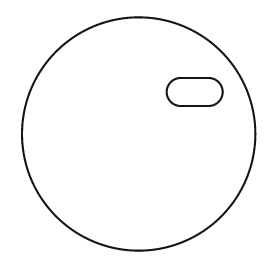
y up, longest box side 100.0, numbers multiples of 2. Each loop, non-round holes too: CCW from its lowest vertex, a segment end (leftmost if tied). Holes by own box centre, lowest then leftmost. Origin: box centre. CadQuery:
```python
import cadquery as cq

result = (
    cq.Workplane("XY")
    .moveTo(0.0, 0.0)
    .circle(50.0)
    .moveTo(18.0, 12.0)
    .lineTo(30.0, 12.0)
    .threePointArc((36.0, 18.0), (30.0, 24.0))
    .lineTo(18.0, 24.0)
    .threePointArc((12.0, 18.0), (18.0, 12.0))
    .close()
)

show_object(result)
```